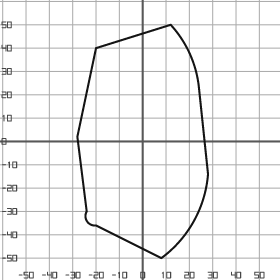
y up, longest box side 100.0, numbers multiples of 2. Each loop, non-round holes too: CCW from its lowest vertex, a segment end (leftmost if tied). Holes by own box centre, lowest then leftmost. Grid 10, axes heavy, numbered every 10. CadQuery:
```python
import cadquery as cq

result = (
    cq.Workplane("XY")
    .moveTo(8.0, -50.0)
    .threePointArc((22.0, -34.0), (28.0, -14.0))
    .lineTo(24.0, 24.0)
    .threePointArc((20.0, 38.0), (12.0, 50.0))
    .lineTo(-20.0, 40.0)
    .lineTo(-28.0, 2.0)
    .lineTo(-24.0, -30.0)
    .threePointArc((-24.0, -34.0), (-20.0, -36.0))
    .close()
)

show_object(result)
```